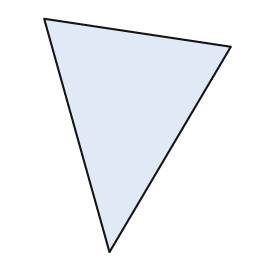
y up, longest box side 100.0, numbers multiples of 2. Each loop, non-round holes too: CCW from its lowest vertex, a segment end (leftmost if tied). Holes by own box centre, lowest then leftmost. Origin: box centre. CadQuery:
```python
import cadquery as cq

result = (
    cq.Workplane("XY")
    .moveTo(-12.0, -50.0)
    .lineTo(40.0, 38.0)
    .lineTo(-40.0, 50.0)
    .close()
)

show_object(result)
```